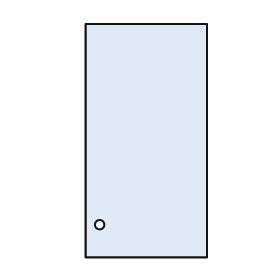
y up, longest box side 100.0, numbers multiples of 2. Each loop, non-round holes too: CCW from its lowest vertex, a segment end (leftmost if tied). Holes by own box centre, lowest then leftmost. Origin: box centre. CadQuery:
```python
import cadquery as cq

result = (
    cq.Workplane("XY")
    .moveTo(-26.0, -50.0)
    .lineTo(26.0, -50.0)
    .lineTo(26.0, 50.0)
    .lineTo(-26.0, 50.0)
    .close()
    .moveTo(-20.0, -36.0)
    .circle(2.0)
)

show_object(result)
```